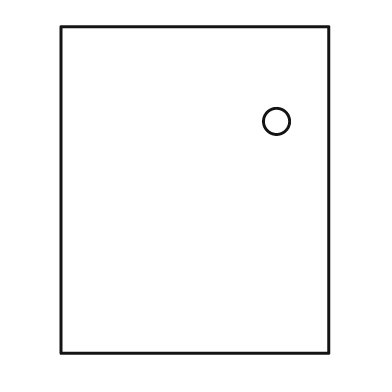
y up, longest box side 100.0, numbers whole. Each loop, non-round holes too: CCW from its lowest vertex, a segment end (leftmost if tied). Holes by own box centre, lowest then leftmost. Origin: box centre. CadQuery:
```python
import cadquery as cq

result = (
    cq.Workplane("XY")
    .moveTo(-41.0, -50.0)
    .lineTo(41.0, -50.0)
    .lineTo(41.0, 50.0)
    .lineTo(-41.0, 50.0)
    .close()
    .moveTo(25.0, 21.0)
    .circle(4.0)
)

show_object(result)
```